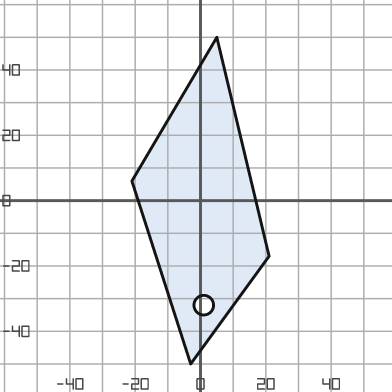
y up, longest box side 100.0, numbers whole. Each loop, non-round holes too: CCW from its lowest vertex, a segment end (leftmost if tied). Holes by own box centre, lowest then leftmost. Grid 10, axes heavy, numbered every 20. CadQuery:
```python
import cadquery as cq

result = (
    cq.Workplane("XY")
    .moveTo(-3.0, -50.0)
    .lineTo(21.0, -17.0)
    .lineTo(5.0, 50.0)
    .lineTo(-21.0, 6.0)
    .close()
    .moveTo(1.0, -32.0)
    .circle(3.0)
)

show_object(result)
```